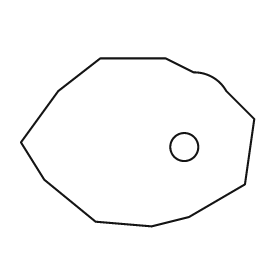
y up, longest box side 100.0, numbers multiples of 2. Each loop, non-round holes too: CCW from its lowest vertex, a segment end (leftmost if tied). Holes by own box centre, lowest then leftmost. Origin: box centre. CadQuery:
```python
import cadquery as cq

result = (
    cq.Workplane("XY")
    .moveTo(6.0, -36.0)
    .lineTo(22.0, -32.0)
    .lineTo(46.0, -18.0)
    .lineTo(50.0, 10.0)
    .lineTo(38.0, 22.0)
    .threePointArc((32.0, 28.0), (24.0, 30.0))
    .lineTo(12.0, 36.0)
    .lineTo(-16.0, 36.0)
    .lineTo(-34.0, 22.0)
    .lineTo(-50.0, 0.0)
    .lineTo(-40.0, -16.0)
    .lineTo(-18.0, -34.0)
    .close()
    .moveTo(20.0, -2.0)
    .circle(6.0)
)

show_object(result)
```